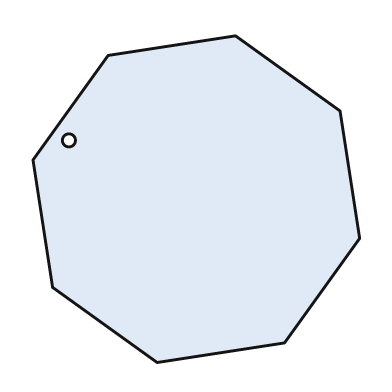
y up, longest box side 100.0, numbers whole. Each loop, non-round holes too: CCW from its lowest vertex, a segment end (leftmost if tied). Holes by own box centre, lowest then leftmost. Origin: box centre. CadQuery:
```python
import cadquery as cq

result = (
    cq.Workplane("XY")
    .moveTo(-12.0, -50.0)
    .lineTo(27.0, -44.0)
    .lineTo(50.0, -12.0)
    .lineTo(44.0, 27.0)
    .lineTo(12.0, 50.0)
    .lineTo(-27.0, 44.0)
    .lineTo(-50.0, 12.0)
    .lineTo(-44.0, -27.0)
    .close()
    .moveTo(-39.0, 18.0)
    .circle(2.0)
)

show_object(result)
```